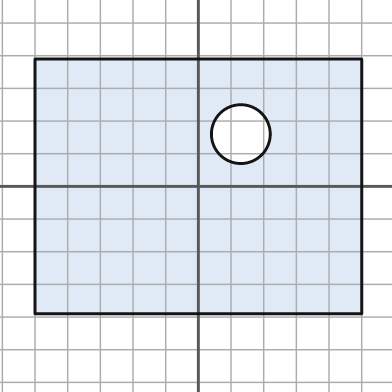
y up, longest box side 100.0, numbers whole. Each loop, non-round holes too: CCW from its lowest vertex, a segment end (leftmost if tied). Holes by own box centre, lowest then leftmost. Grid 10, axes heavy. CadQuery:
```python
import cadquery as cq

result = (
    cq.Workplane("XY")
    .moveTo(-50.0, -39.0)
    .lineTo(50.0, -39.0)
    .lineTo(50.0, 39.0)
    .lineTo(-50.0, 39.0)
    .close()
    .moveTo(13.0, 16.0)
    .circle(9.0)
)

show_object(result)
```